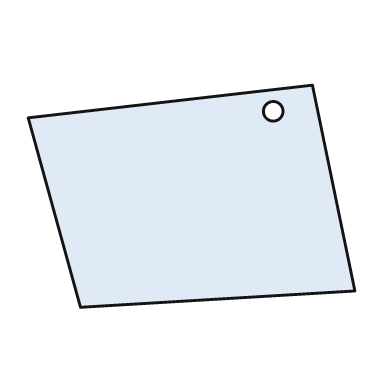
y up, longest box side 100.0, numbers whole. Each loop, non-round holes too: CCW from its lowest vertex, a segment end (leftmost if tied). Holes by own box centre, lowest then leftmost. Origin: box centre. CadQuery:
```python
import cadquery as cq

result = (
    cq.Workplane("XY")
    .moveTo(-34.0, -34.0)
    .lineTo(50.0, -29.0)
    .lineTo(37.0, 34.0)
    .lineTo(-50.0, 24.0)
    .close()
    .moveTo(25.0, 26.0)
    .circle(3.0)
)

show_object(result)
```